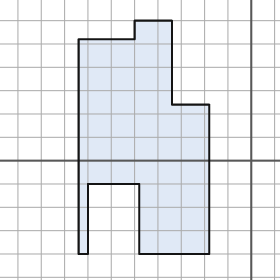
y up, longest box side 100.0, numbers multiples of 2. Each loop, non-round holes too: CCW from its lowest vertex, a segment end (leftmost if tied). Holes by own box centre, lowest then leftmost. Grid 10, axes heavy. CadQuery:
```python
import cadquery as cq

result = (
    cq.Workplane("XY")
    .moveTo(-74.0, -40.0)
    .lineTo(-70.0, -40.0)
    .lineTo(-70.0, -10.0)
    .lineTo(-48.0, -10.0)
    .lineTo(-48.0, -40.0)
    .lineTo(-18.0, -40.0)
    .lineTo(-18.0, 24.0)
    .lineTo(-34.0, 24.0)
    .lineTo(-34.0, 60.0)
    .lineTo(-50.0, 60.0)
    .lineTo(-50.0, 52.0)
    .lineTo(-74.0, 52.0)
    .close()
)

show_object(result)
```